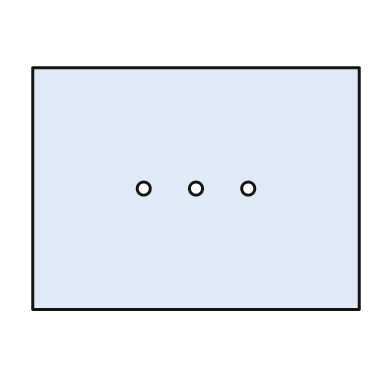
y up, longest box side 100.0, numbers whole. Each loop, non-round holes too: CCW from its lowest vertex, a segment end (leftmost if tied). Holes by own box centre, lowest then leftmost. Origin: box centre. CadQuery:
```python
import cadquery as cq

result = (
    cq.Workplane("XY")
    .moveTo(-50.0, -37.0)
    .lineTo(50.0, -37.0)
    .lineTo(50.0, 37.0)
    .lineTo(-50.0, 37.0)
    .close()
    .moveTo(-16.0, 0.0)
    .circle(2.0)
    .moveTo(0.0, 0.0)
    .circle(2.0)
    .moveTo(16.0, 0.0)
    .circle(2.0)
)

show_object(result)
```